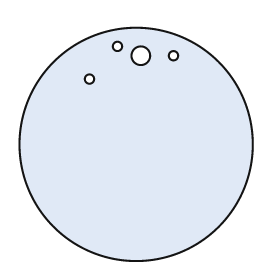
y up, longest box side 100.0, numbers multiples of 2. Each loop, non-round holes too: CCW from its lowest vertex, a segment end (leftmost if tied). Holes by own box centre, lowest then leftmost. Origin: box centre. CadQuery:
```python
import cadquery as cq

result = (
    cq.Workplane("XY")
    .moveTo(0.0, 0.0)
    .circle(50.0)
    .moveTo(-20.0, 28.0)
    .circle(2.0)
    .moveTo(2.0, 38.0)
    .circle(4.0)
    .moveTo(16.0, 38.0)
    .circle(2.0)
    .moveTo(-8.0, 42.0)
    .circle(2.0)
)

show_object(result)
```